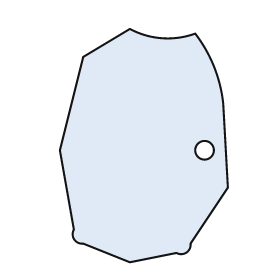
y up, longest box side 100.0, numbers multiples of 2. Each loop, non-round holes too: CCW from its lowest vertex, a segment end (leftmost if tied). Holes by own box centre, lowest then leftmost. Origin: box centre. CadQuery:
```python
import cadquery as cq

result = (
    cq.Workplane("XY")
    .moveTo(-6.0, -50.0)
    .lineTo(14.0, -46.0)
    .threePointArc((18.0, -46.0), (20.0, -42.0))
    .lineTo(36.0, -18.0)
    .lineTo(34.0, 18.0)
    .threePointArc((30.0, 34.0), (22.0, 48.0))
    .threePointArc((8.0, 46.0), (-6.0, 50.0))
    .lineTo(-26.0, 38.0)
    .lineTo(-36.0, -2.0)
    .lineTo(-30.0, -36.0)
    .threePointArc((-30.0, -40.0), (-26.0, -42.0))
    .close()
    .moveTo(26.0, -2.0)
    .circle(4.0)
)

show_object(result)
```